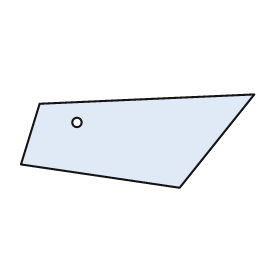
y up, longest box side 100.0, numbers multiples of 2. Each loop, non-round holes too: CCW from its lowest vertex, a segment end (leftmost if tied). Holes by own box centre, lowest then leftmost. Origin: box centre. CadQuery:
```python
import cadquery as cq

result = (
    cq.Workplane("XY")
    .moveTo(18.0, -20.0)
    .lineTo(50.0, 20.0)
    .lineTo(-42.0, 16.0)
    .lineTo(-50.0, -10.0)
    .close()
    .moveTo(-26.0, 8.0)
    .circle(2.0)
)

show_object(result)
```